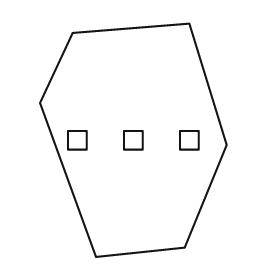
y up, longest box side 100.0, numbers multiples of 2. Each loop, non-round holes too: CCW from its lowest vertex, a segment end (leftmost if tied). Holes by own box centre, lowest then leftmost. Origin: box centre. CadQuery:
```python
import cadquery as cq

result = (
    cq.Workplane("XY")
    .moveTo(-16.0, -50.0)
    .lineTo(22.0, -46.0)
    .lineTo(40.0, -2.0)
    .lineTo(24.0, 50.0)
    .lineTo(-26.0, 46.0)
    .lineTo(-40.0, 16.0)
    .close()
    .moveTo(-28.0, -4.0)
    .lineTo(-20.0, -4.0)
    .lineTo(-20.0, 4.0)
    .lineTo(-28.0, 4.0)
    .close()
    .moveTo(-4.0, -4.0)
    .lineTo(4.0, -4.0)
    .lineTo(4.0, 4.0)
    .lineTo(-4.0, 4.0)
    .close()
    .moveTo(20.0, -4.0)
    .lineTo(28.0, -4.0)
    .lineTo(28.0, 4.0)
    .lineTo(20.0, 4.0)
    .close()
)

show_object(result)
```